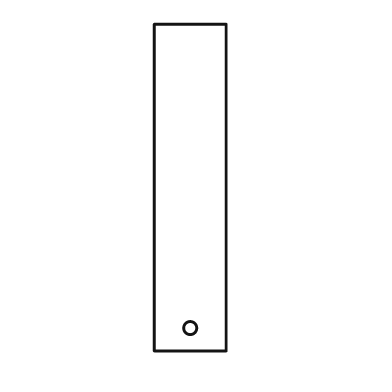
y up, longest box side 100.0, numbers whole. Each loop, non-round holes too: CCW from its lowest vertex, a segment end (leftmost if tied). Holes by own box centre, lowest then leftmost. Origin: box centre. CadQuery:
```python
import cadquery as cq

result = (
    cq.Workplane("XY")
    .moveTo(-11.0, -50.0)
    .lineTo(11.0, -50.0)
    .lineTo(11.0, 50.0)
    .lineTo(-11.0, 50.0)
    .close()
    .moveTo(0.0, -43.0)
    .circle(2.0)
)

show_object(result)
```